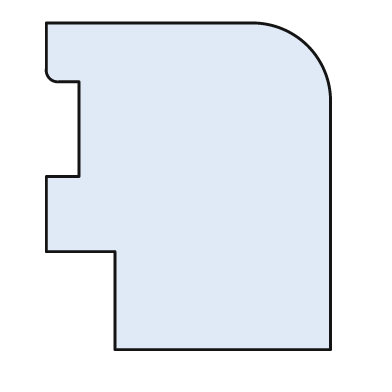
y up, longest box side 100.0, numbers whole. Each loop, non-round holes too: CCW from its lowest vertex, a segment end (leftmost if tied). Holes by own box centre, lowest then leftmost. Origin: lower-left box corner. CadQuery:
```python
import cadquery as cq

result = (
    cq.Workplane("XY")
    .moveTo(21.0, 0.0)
    .lineTo(87.0, 0.0)
    .lineTo(87.0, 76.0)
    .threePointArc((80.0, 93.0), (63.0, 100.0))
    .lineTo(0.0, 100.0)
    .lineTo(0.0, 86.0)
    .threePointArc((1.0, 83.0), (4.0, 82.0))
    .lineTo(10.0, 82.0)
    .lineTo(10.0, 53.0)
    .lineTo(0.0, 53.0)
    .lineTo(0.0, 30.0)
    .lineTo(21.0, 30.0)
    .close()
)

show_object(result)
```